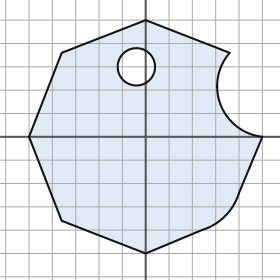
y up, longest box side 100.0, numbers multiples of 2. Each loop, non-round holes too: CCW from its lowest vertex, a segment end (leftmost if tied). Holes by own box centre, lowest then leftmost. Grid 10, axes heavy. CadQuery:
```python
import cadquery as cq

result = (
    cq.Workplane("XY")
    .moveTo(0.0, -50.0)
    .lineTo(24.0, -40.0)
    .threePointArc((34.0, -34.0), (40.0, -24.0))
    .lineTo(50.0, 0.0)
    .threePointArc((32.0, 14.0), (36.0, 36.0))
    .lineTo(0.0, 50.0)
    .lineTo(-36.0, 36.0)
    .lineTo(-50.0, 0.0)
    .lineTo(-36.0, -36.0)
    .close()
    .moveTo(-4.0, 30.0)
    .circle(8.0)
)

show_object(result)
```